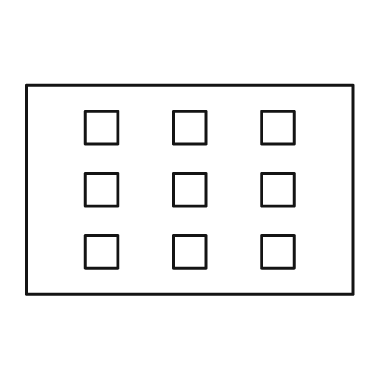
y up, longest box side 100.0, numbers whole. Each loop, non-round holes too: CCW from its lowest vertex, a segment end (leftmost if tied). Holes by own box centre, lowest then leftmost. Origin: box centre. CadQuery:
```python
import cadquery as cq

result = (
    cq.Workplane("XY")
    .moveTo(-50.0, -32.0)
    .lineTo(50.0, -32.0)
    .lineTo(50.0, 32.0)
    .lineTo(-50.0, 32.0)
    .close()
    .moveTo(-32.0, -24.0)
    .lineTo(-22.0, -24.0)
    .lineTo(-22.0, -14.0)
    .lineTo(-32.0, -14.0)
    .close()
    .moveTo(-5.0, -24.0)
    .lineTo(5.0, -24.0)
    .lineTo(5.0, -14.0)
    .lineTo(-5.0, -14.0)
    .close()
    .moveTo(22.0, -24.0)
    .lineTo(32.0, -24.0)
    .lineTo(32.0, -14.0)
    .lineTo(22.0, -14.0)
    .close()
    .moveTo(-32.0, -5.0)
    .lineTo(-22.0, -5.0)
    .lineTo(-22.0, 5.0)
    .lineTo(-32.0, 5.0)
    .close()
    .moveTo(-5.0, -5.0)
    .lineTo(5.0, -5.0)
    .lineTo(5.0, 5.0)
    .lineTo(-5.0, 5.0)
    .close()
    .moveTo(22.0, -5.0)
    .lineTo(32.0, -5.0)
    .lineTo(32.0, 5.0)
    .lineTo(22.0, 5.0)
    .close()
    .moveTo(-32.0, 14.0)
    .lineTo(-22.0, 14.0)
    .lineTo(-22.0, 24.0)
    .lineTo(-32.0, 24.0)
    .close()
    .moveTo(-5.0, 14.0)
    .lineTo(5.0, 14.0)
    .lineTo(5.0, 24.0)
    .lineTo(-5.0, 24.0)
    .close()
    .moveTo(22.0, 14.0)
    .lineTo(32.0, 14.0)
    .lineTo(32.0, 24.0)
    .lineTo(22.0, 24.0)
    .close()
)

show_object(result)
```